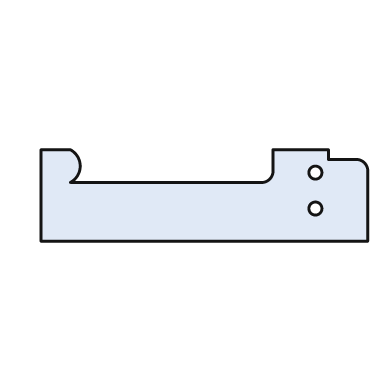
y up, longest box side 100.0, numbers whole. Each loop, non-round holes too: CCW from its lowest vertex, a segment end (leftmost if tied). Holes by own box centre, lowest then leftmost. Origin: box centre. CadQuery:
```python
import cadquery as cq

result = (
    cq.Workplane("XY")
    .moveTo(-50.0, -14.0)
    .lineTo(50.0, -14.0)
    .lineTo(50.0, 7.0)
    .threePointArc((49.0, 10.0), (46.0, 11.0))
    .lineTo(38.0, 11.0)
    .lineTo(38.0, 14.0)
    .lineTo(21.0, 14.0)
    .lineTo(21.0, 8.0)
    .threePointArc((20.0, 5.0), (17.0, 4.0))
    .lineTo(-41.0, 4.0)
    .threePointArc((-38.0, 9.0), (-41.0, 14.0))
    .lineTo(-50.0, 14.0)
    .close()
    .moveTo(34.0, -4.0)
    .circle(2.0)
    .moveTo(34.0, 7.0)
    .circle(2.0)
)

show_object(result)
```